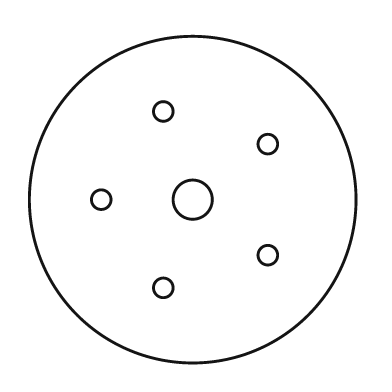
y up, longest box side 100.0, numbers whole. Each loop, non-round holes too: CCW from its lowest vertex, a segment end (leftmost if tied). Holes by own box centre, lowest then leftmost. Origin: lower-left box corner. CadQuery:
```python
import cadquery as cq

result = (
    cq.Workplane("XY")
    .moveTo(50.0, 50.0)
    .circle(50.0)
    .moveTo(41.0, 23.0)
    .circle(3.0)
    .moveTo(73.0, 33.0)
    .circle(3.0)
    .moveTo(22.0, 50.0)
    .circle(3.0)
    .moveTo(50.0, 50.0)
    .circle(6.0)
    .moveTo(73.0, 67.0)
    .circle(3.0)
    .moveTo(41.0, 77.0)
    .circle(3.0)
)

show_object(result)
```